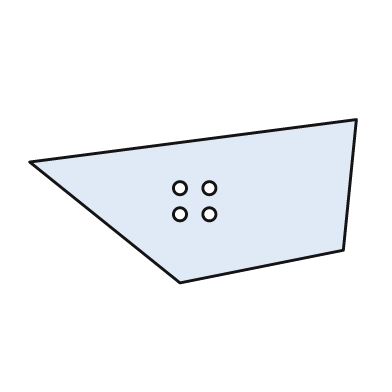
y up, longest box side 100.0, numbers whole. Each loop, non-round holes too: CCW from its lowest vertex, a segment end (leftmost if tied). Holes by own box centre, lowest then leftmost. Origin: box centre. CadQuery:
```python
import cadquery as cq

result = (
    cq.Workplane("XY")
    .moveTo(-4.0, -25.0)
    .lineTo(46.0, -15.0)
    .lineTo(50.0, 25.0)
    .lineTo(-50.0, 12.0)
    .close()
    .moveTo(-4.0, -4.0)
    .circle(2.0)
    .moveTo(5.0, -4.0)
    .circle(2.0)
    .moveTo(-4.0, 4.0)
    .circle(2.0)
    .moveTo(5.0, 4.0)
    .circle(2.0)
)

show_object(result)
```